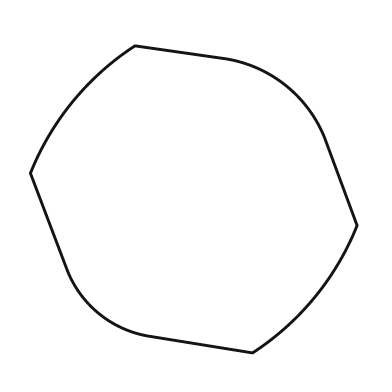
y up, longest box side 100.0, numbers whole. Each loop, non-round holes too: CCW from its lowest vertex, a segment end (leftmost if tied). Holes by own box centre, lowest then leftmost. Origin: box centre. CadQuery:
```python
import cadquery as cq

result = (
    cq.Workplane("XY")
    .moveTo(18.0, -47.0)
    .threePointArc((37.0, -30.0), (50.0, -8.0))
    .lineTo(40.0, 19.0)
    .threePointArc((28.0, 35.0), (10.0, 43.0))
    .lineTo(-18.0, 47.0)
    .threePointArc((-37.0, 30.0), (-50.0, 8.0))
    .lineTo(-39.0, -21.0)
    .threePointArc((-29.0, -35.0), (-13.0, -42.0))
    .close()
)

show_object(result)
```